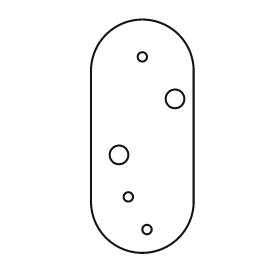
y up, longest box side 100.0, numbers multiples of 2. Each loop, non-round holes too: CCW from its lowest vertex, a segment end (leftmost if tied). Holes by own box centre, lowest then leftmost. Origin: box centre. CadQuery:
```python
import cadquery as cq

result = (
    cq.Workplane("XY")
    .moveTo(-22.0, -28.0)
    .threePointArc((0.0, -50.0), (22.0, -28.0))
    .lineTo(22.0, 28.0)
    .threePointArc((0.0, 50.0), (-22.0, 28.0))
    .close()
    .moveTo(2.0, -40.0)
    .circle(2.0)
    .moveTo(-6.0, -26.0)
    .circle(2.0)
    .moveTo(-10.0, -8.0)
    .circle(4.0)
    .moveTo(14.0, 16.0)
    .circle(4.0)
    .moveTo(0.0, 34.0)
    .circle(2.0)
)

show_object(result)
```